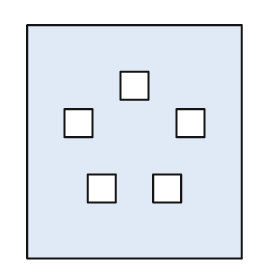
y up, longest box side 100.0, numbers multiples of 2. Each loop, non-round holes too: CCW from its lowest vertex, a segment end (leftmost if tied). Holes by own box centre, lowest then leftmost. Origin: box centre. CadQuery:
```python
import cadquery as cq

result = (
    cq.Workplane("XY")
    .moveTo(-46.0, -50.0)
    .lineTo(46.0, -50.0)
    .lineTo(46.0, 50.0)
    .lineTo(-46.0, 50.0)
    .close()
    .moveTo(-20.0, -26.0)
    .lineTo(-8.0, -26.0)
    .lineTo(-8.0, -14.0)
    .lineTo(-20.0, -14.0)
    .close()
    .moveTo(8.0, -26.0)
    .lineTo(20.0, -26.0)
    .lineTo(20.0, -14.0)
    .lineTo(8.0, -14.0)
    .close()
    .moveTo(-30.0, 2.0)
    .lineTo(-18.0, 2.0)
    .lineTo(-18.0, 14.0)
    .lineTo(-30.0, 14.0)
    .close()
    .moveTo(18.0, 2.0)
    .lineTo(30.0, 2.0)
    .lineTo(30.0, 14.0)
    .lineTo(18.0, 14.0)
    .close()
    .moveTo(-6.0, 18.0)
    .lineTo(6.0, 18.0)
    .lineTo(6.0, 30.0)
    .lineTo(-6.0, 30.0)
    .close()
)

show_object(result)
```